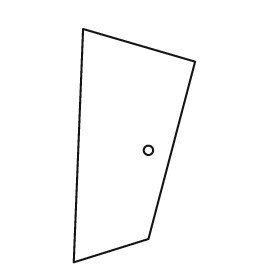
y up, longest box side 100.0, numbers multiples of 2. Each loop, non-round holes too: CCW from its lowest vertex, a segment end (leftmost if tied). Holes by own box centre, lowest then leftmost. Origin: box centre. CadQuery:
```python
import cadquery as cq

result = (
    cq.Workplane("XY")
    .moveTo(-26.0, -50.0)
    .lineTo(6.0, -40.0)
    .lineTo(26.0, 36.0)
    .lineTo(-22.0, 50.0)
    .close()
    .moveTo(6.0, -2.0)
    .circle(2.0)
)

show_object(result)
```